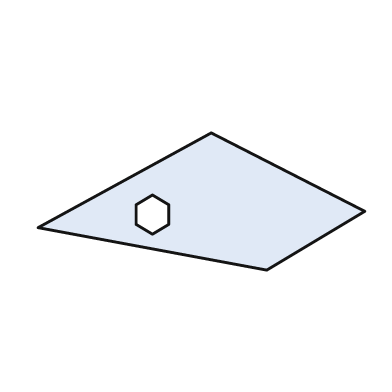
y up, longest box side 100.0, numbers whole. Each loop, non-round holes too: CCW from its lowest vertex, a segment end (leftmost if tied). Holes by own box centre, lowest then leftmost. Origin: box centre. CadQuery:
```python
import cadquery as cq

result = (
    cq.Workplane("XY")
    .moveTo(20.0, -21.0)
    .lineTo(50.0, -3.0)
    .lineTo(3.0, 21.0)
    .lineTo(-50.0, -8.0)
    .close()
    .moveTo(-15.0, -10.0)
    .lineTo(-10.0, -7.0)
    .lineTo(-10.0, -1.0)
    .lineTo(-15.0, 2.0)
    .lineTo(-20.0, -1.0)
    .lineTo(-20.0, -7.0)
    .close()
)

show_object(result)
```